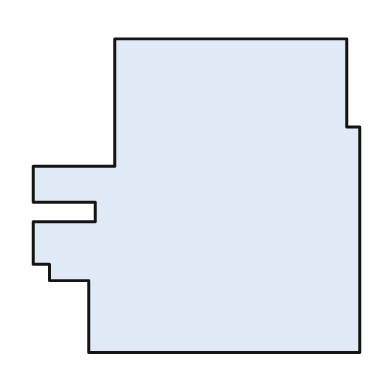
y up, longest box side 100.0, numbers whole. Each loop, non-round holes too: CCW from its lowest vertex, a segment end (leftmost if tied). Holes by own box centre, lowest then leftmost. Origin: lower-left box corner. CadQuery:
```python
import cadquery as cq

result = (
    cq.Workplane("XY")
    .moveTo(17.0, 0.0)
    .lineTo(100.0, 0.0)
    .lineTo(100.0, 69.0)
    .lineTo(96.0, 69.0)
    .lineTo(96.0, 96.0)
    .lineTo(25.0, 96.0)
    .lineTo(25.0, 57.0)
    .lineTo(0.0, 57.0)
    .lineTo(0.0, 46.0)
    .lineTo(19.0, 46.0)
    .lineTo(19.0, 40.0)
    .lineTo(0.0, 40.0)
    .lineTo(0.0, 27.0)
    .lineTo(5.0, 27.0)
    .lineTo(5.0, 22.0)
    .lineTo(17.0, 22.0)
    .close()
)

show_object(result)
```